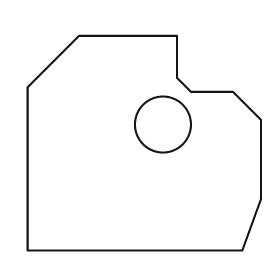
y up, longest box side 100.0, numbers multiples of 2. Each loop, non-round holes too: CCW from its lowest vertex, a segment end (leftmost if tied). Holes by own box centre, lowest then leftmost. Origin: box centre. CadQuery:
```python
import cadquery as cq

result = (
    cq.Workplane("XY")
    .moveTo(-50.0, -46.0)
    .lineTo(42.0, -46.0)
    .lineTo(50.0, -24.0)
    .lineTo(50.0, 10.0)
    .lineTo(38.0, 22.0)
    .lineTo(20.0, 22.0)
    .lineTo(14.0, 28.0)
    .lineTo(14.0, 46.0)
    .lineTo(-28.0, 46.0)
    .lineTo(-50.0, 24.0)
    .close()
    .moveTo(8.0, 8.0)
    .circle(12.0)
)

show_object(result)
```